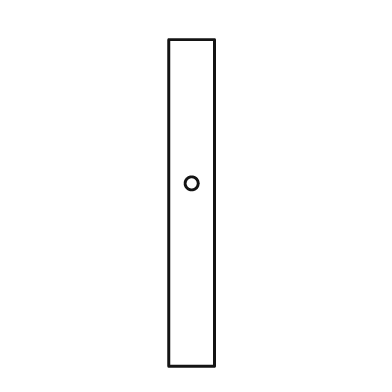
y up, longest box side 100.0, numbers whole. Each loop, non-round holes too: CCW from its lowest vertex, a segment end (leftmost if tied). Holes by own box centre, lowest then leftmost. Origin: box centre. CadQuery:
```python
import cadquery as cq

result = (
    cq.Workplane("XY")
    .moveTo(-7.0, -50.0)
    .lineTo(7.0, -50.0)
    .lineTo(7.0, 50.0)
    .lineTo(-7.0, 50.0)
    .close()
    .moveTo(0.0, 6.0)
    .circle(2.0)
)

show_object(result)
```